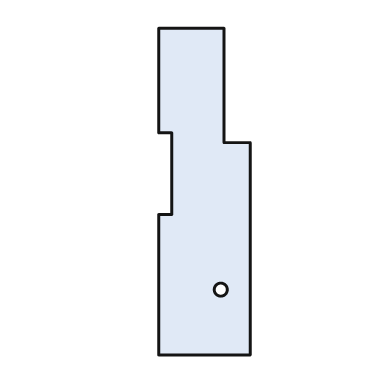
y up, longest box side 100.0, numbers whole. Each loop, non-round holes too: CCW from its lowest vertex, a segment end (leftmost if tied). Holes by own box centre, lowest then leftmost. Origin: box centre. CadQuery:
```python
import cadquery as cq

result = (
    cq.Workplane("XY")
    .moveTo(-14.0, -50.0)
    .lineTo(14.0, -50.0)
    .lineTo(14.0, 15.0)
    .lineTo(6.0, 15.0)
    .lineTo(6.0, 50.0)
    .lineTo(-14.0, 50.0)
    .lineTo(-14.0, 18.0)
    .lineTo(-10.0, 18.0)
    .lineTo(-10.0, -7.0)
    .lineTo(-14.0, -7.0)
    .close()
    .moveTo(5.0, -30.0)
    .circle(2.0)
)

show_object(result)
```